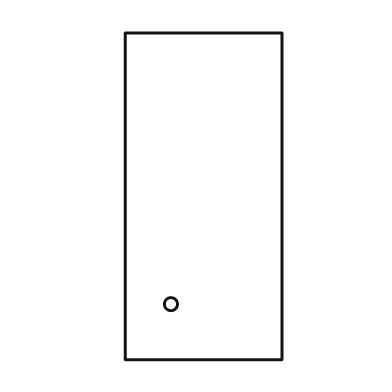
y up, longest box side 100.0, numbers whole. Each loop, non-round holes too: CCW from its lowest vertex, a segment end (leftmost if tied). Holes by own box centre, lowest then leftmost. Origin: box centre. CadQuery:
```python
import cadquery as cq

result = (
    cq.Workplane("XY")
    .moveTo(-24.0, -50.0)
    .lineTo(24.0, -50.0)
    .lineTo(24.0, 50.0)
    .lineTo(-24.0, 50.0)
    .close()
    .moveTo(-10.0, -33.0)
    .circle(2.0)
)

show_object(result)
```